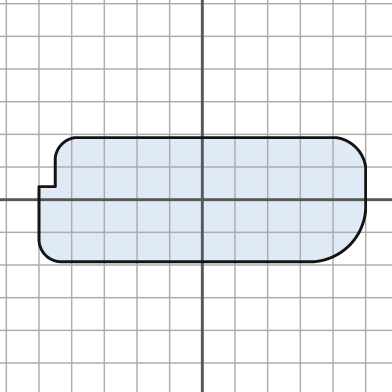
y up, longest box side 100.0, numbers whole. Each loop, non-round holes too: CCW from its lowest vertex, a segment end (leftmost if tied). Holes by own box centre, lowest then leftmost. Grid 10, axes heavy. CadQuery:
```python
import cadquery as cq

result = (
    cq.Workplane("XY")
    .moveTo(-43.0, -19.0)
    .lineTo(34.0, -19.0)
    .threePointArc((45.0, -14.0), (50.0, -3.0))
    .lineTo(50.0, 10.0)
    .threePointArc((47.0, 16.0), (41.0, 19.0))
    .lineTo(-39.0, 19.0)
    .threePointArc((-43.0, 17.0), (-45.0, 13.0))
    .lineTo(-45.0, 4.0)
    .lineTo(-50.0, 4.0)
    .lineTo(-50.0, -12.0)
    .threePointArc((-48.0, -17.0), (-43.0, -19.0))
    .close()
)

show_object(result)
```